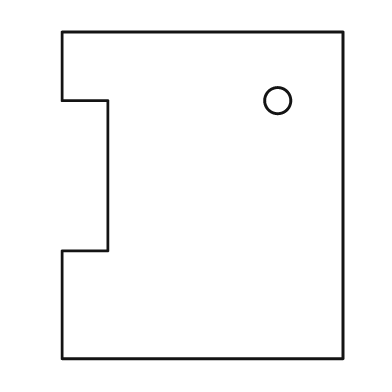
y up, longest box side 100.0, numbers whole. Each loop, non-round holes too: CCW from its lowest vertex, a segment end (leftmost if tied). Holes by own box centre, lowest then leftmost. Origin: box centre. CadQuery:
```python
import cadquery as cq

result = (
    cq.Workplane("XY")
    .moveTo(-43.0, -50.0)
    .lineTo(43.0, -50.0)
    .lineTo(43.0, 50.0)
    .lineTo(-43.0, 50.0)
    .lineTo(-43.0, 29.0)
    .lineTo(-29.0, 29.0)
    .lineTo(-29.0, -17.0)
    .lineTo(-43.0, -17.0)
    .close()
    .moveTo(23.0, 29.0)
    .circle(4.0)
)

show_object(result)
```